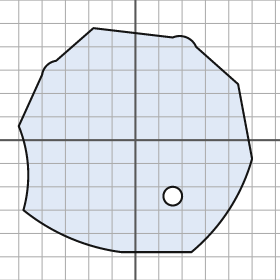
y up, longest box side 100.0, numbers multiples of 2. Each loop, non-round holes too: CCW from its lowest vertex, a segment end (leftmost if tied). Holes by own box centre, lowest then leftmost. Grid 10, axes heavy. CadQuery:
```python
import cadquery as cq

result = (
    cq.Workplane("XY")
    .moveTo(-6.0, -48.0)
    .lineTo(24.0, -48.0)
    .threePointArc((40.0, -30.0), (50.0, -8.0))
    .lineTo(44.0, 24.0)
    .lineTo(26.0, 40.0)
    .threePointArc((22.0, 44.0), (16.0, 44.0))
    .lineTo(-18.0, 48.0)
    .lineTo(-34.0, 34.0)
    .threePointArc((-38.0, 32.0), (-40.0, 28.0))
    .lineTo(-50.0, 6.0)
    .threePointArc((-46.0, -12.0), (-48.0, -30.0))
    .threePointArc((-28.0, -42.0), (-6.0, -48.0))
    .close()
    .moveTo(16.0, -24.0)
    .circle(4.0)
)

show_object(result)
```